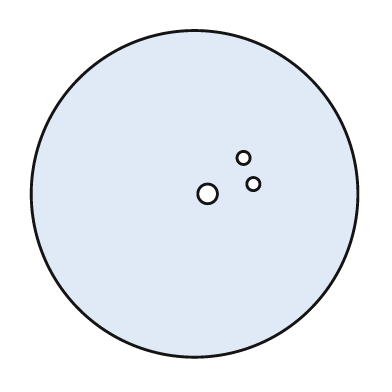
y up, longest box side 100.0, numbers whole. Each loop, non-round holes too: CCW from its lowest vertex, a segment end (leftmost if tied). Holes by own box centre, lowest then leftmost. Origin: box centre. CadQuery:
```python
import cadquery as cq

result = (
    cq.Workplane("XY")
    .moveTo(0.0, 0.0)
    .circle(50.0)
    .moveTo(4.0, 0.0)
    .circle(3.0)
    .moveTo(18.0, 3.0)
    .circle(2.0)
    .moveTo(15.0, 11.0)
    .circle(2.0)
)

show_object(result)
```